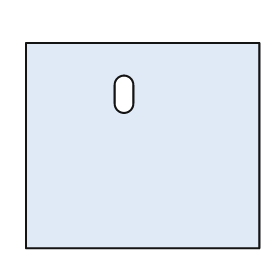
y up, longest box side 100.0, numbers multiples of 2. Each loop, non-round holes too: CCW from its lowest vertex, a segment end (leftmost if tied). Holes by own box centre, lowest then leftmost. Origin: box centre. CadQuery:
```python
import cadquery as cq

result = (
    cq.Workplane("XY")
    .moveTo(-50.0, -44.0)
    .lineTo(50.0, -44.0)
    .lineTo(50.0, 44.0)
    .lineTo(-50.0, 44.0)
    .close()
    .moveTo(-12.0, 18.0)
    .threePointArc((-8.0, 14.0), (-4.0, 18.0))
    .lineTo(-4.0, 26.0)
    .threePointArc((-8.0, 30.0), (-12.0, 26.0))
    .close()
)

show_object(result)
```